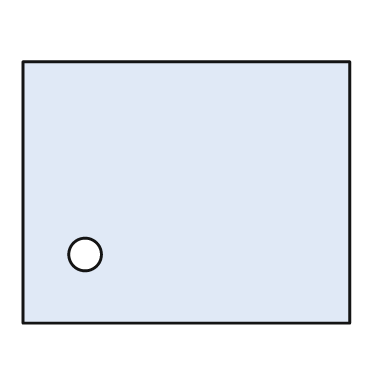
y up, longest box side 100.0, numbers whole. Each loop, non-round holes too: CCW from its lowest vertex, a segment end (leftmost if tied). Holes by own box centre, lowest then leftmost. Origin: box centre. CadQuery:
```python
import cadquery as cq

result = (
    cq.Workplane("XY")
    .moveTo(-50.0, -40.0)
    .lineTo(50.0, -40.0)
    .lineTo(50.0, 40.0)
    .lineTo(-50.0, 40.0)
    .close()
    .moveTo(-31.0, -19.0)
    .circle(5.0)
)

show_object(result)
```